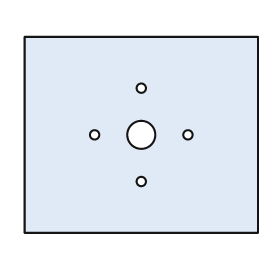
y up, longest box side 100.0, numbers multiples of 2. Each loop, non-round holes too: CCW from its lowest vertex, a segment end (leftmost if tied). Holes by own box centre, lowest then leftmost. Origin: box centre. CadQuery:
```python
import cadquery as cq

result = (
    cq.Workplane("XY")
    .moveTo(-50.0, -42.0)
    .lineTo(50.0, -42.0)
    .lineTo(50.0, 42.0)
    .lineTo(-50.0, 42.0)
    .close()
    .moveTo(0.0, -20.0)
    .circle(2.0)
    .moveTo(-20.0, 0.0)
    .circle(2.0)
    .moveTo(0.0, 0.0)
    .circle(6.0)
    .moveTo(20.0, 0.0)
    .circle(2.0)
    .moveTo(0.0, 20.0)
    .circle(2.0)
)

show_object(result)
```